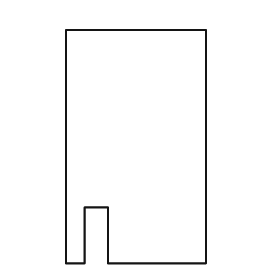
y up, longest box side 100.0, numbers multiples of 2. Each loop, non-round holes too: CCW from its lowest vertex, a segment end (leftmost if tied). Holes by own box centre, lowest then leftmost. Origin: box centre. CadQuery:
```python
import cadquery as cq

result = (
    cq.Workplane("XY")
    .moveTo(-30.0, -50.0)
    .lineTo(-22.0, -50.0)
    .lineTo(-22.0, -26.0)
    .lineTo(-12.0, -26.0)
    .lineTo(-12.0, -50.0)
    .lineTo(30.0, -50.0)
    .lineTo(30.0, 50.0)
    .lineTo(-30.0, 50.0)
    .close()
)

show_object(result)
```